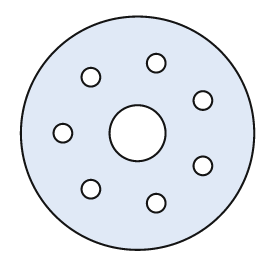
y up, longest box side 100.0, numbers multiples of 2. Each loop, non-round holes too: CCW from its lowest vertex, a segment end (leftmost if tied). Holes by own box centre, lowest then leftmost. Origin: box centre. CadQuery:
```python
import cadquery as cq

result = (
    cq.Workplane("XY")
    .moveTo(0.0, 0.0)
    .circle(50.0)
    .moveTo(8.0, -30.0)
    .circle(4.0)
    .moveTo(-20.0, -24.0)
    .circle(4.0)
    .moveTo(28.0, -14.0)
    .circle(4.0)
    .moveTo(-32.0, 0.0)
    .circle(4.0)
    .moveTo(0.0, 0.0)
    .circle(12.0)
    .moveTo(28.0, 14.0)
    .circle(4.0)
    .moveTo(-20.0, 24.0)
    .circle(4.0)
    .moveTo(8.0, 30.0)
    .circle(4.0)
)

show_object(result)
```